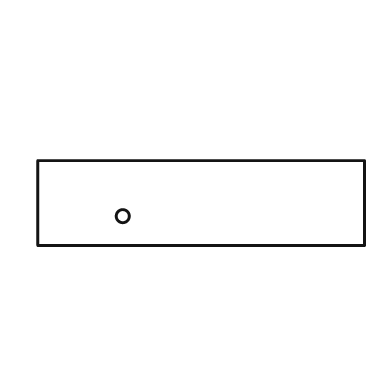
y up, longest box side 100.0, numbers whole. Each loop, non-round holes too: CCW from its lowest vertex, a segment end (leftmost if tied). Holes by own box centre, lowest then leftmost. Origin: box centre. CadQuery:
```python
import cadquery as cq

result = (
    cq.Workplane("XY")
    .moveTo(-50.0, -13.0)
    .lineTo(50.0, -13.0)
    .lineTo(50.0, 13.0)
    .lineTo(-50.0, 13.0)
    .close()
    .moveTo(-24.0, -4.0)
    .circle(2.0)
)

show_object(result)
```